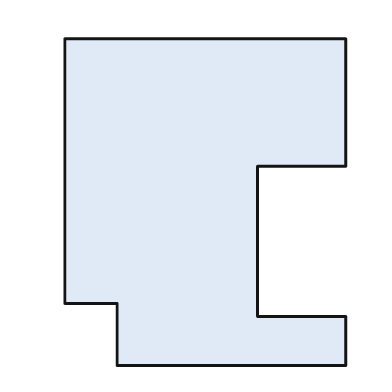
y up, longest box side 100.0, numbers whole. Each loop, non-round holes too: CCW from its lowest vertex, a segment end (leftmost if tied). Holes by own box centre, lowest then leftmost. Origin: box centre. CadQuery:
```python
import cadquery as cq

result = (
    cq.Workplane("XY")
    .moveTo(-27.0, -50.0)
    .lineTo(43.0, -50.0)
    .lineTo(43.0, -35.0)
    .lineTo(16.0, -35.0)
    .lineTo(16.0, 11.0)
    .lineTo(43.0, 11.0)
    .lineTo(43.0, 50.0)
    .lineTo(-43.0, 50.0)
    .lineTo(-43.0, -31.0)
    .lineTo(-27.0, -31.0)
    .close()
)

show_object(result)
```